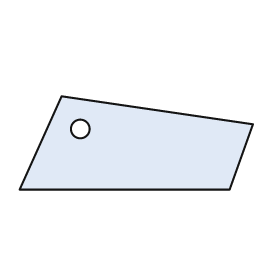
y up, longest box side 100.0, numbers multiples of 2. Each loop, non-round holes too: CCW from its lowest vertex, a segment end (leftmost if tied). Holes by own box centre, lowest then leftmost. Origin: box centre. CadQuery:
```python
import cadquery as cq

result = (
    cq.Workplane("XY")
    .moveTo(-50.0, -20.0)
    .lineTo(40.0, -20.0)
    .lineTo(50.0, 8.0)
    .lineTo(-32.0, 20.0)
    .close()
    .moveTo(-24.0, 6.0)
    .circle(4.0)
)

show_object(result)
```